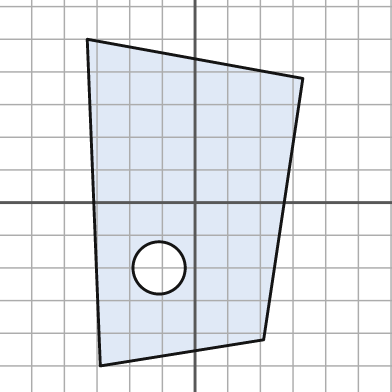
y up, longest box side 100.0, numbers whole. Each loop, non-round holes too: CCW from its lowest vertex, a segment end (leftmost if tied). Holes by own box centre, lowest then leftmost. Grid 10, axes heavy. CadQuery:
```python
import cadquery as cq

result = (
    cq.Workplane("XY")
    .moveTo(-29.0, -50.0)
    .lineTo(21.0, -42.0)
    .lineTo(33.0, 38.0)
    .lineTo(-33.0, 50.0)
    .close()
    .moveTo(-11.0, -20.0)
    .circle(8.0)
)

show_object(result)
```